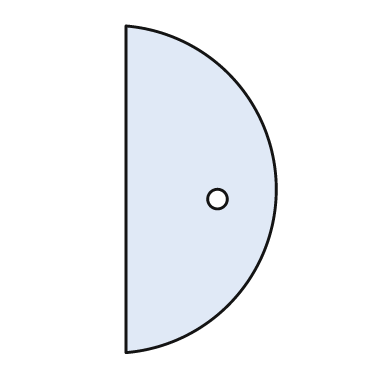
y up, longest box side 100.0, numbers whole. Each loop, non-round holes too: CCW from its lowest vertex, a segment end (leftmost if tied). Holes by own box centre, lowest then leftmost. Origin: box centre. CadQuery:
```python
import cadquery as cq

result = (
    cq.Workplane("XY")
    .moveTo(-23.0, -50.0)
    .threePointArc((23.0, 0.0), (-23.0, 50.0))
    .close()
    .moveTo(5.0, -3.0)
    .circle(3.0)
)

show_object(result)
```